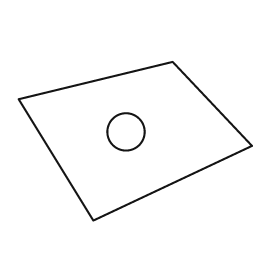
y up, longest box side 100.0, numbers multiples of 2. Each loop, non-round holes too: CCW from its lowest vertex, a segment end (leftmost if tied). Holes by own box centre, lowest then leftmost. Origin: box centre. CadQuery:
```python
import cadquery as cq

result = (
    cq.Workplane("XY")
    .moveTo(-18.0, -34.0)
    .lineTo(50.0, -2.0)
    .lineTo(16.0, 34.0)
    .lineTo(-50.0, 18.0)
    .close()
    .moveTo(-4.0, 4.0)
    .circle(8.0)
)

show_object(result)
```